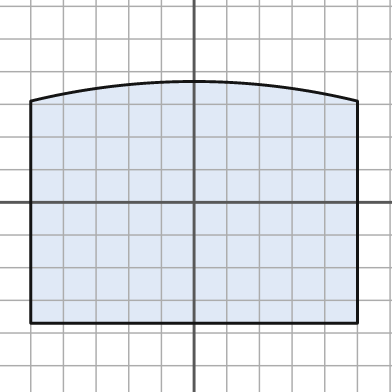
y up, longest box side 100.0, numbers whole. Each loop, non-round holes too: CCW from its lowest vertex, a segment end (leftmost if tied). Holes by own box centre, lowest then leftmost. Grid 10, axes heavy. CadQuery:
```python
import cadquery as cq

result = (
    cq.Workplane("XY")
    .moveTo(-50.0, -37.0)
    .lineTo(50.0, -37.0)
    .lineTo(50.0, 31.0)
    .threePointArc((0.0, 37.0), (-50.0, 31.0))
    .close()
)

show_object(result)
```